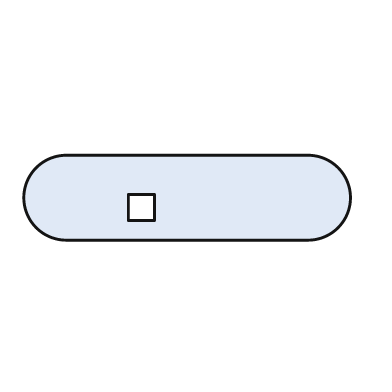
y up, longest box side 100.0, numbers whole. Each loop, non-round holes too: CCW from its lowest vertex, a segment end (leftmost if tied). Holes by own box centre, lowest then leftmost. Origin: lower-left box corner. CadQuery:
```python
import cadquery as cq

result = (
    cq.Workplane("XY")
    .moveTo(13.0, 0.0)
    .lineTo(87.0, 0.0)
    .threePointArc((100.0, 13.0), (87.0, 26.0))
    .lineTo(13.0, 26.0)
    .threePointArc((0.0, 13.0), (13.0, 0.0))
    .close()
    .moveTo(32.0, 6.0)
    .lineTo(40.0, 6.0)
    .lineTo(40.0, 14.0)
    .lineTo(32.0, 14.0)
    .close()
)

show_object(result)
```